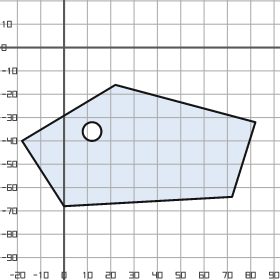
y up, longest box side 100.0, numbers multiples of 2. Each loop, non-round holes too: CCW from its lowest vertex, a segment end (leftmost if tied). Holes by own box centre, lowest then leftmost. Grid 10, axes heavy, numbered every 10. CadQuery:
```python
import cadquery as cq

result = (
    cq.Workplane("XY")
    .moveTo(0.0, -68.0)
    .lineTo(72.0, -64.0)
    .lineTo(82.0, -32.0)
    .lineTo(22.0, -16.0)
    .lineTo(-18.0, -40.0)
    .close()
    .moveTo(12.0, -36.0)
    .circle(4.0)
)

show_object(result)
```